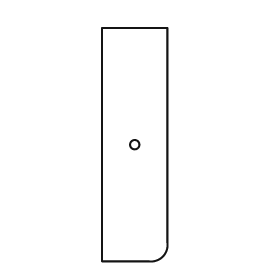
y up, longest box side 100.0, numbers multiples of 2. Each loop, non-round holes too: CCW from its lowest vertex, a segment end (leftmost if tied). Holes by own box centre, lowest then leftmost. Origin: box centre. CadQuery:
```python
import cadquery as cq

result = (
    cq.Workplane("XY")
    .moveTo(-14.0, -50.0)
    .lineTo(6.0, -50.0)
    .threePointArc((12.0, -48.0), (14.0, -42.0))
    .lineTo(14.0, 50.0)
    .lineTo(-14.0, 50.0)
    .close()
    .moveTo(0.0, 0.0)
    .circle(2.0)
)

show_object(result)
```